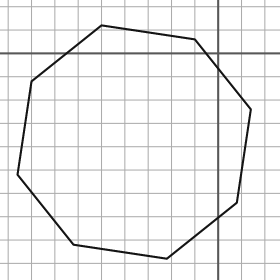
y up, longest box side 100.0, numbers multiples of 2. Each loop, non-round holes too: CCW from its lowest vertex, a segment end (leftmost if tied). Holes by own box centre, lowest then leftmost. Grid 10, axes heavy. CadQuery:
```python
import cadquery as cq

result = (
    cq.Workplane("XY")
    .moveTo(-22.0, -88.0)
    .lineTo(8.0, -64.0)
    .lineTo(14.0, -24.0)
    .lineTo(-10.0, 6.0)
    .lineTo(-50.0, 12.0)
    .lineTo(-80.0, -12.0)
    .lineTo(-86.0, -52.0)
    .lineTo(-62.0, -82.0)
    .close()
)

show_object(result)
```